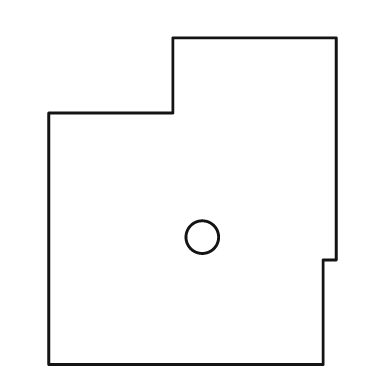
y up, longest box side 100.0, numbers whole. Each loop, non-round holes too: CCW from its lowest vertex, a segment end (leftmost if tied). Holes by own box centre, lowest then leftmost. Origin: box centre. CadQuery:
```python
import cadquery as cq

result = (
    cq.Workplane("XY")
    .moveTo(-44.0, -50.0)
    .lineTo(40.0, -50.0)
    .lineTo(40.0, -18.0)
    .lineTo(44.0, -18.0)
    .lineTo(44.0, 50.0)
    .lineTo(-6.0, 50.0)
    .lineTo(-6.0, 27.0)
    .lineTo(-44.0, 27.0)
    .close()
    .moveTo(3.0, -11.0)
    .circle(5.0)
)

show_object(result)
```